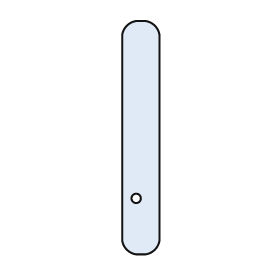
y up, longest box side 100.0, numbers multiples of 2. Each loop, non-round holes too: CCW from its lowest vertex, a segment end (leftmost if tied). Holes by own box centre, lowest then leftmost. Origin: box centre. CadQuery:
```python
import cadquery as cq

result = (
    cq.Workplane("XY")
    .moveTo(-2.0, -50.0)
    .lineTo(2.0, -50.0)
    .threePointArc((6.0, -48.0), (8.0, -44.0))
    .lineTo(8.0, 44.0)
    .threePointArc((6.0, 48.0), (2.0, 50.0))
    .lineTo(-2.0, 50.0)
    .threePointArc((-6.0, 48.0), (-8.0, 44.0))
    .lineTo(-8.0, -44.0)
    .threePointArc((-6.0, -48.0), (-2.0, -50.0))
    .close()
    .moveTo(-2.0, -26.0)
    .circle(2.0)
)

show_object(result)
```